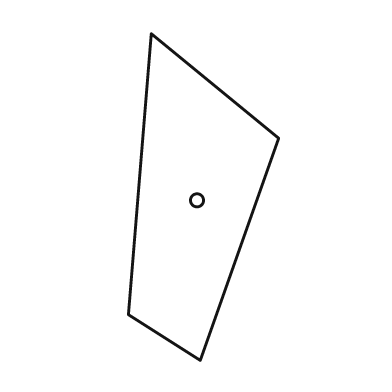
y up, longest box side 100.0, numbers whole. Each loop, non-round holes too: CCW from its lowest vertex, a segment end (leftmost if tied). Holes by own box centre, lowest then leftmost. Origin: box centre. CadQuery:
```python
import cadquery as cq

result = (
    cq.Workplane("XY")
    .moveTo(-1.0, -50.0)
    .lineTo(23.0, 18.0)
    .lineTo(-16.0, 50.0)
    .lineTo(-23.0, -36.0)
    .close()
    .moveTo(-2.0, -1.0)
    .circle(2.0)
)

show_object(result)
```